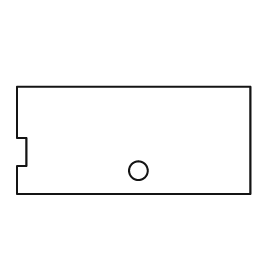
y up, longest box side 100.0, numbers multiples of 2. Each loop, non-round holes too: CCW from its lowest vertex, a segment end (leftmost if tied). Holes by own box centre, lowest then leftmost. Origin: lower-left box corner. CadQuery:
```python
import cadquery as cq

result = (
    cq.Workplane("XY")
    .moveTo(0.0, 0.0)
    .lineTo(100.0, 0.0)
    .lineTo(100.0, 46.0)
    .lineTo(0.0, 46.0)
    .lineTo(0.0, 24.0)
    .lineTo(4.0, 24.0)
    .lineTo(4.0, 12.0)
    .lineTo(0.0, 12.0)
    .close()
    .moveTo(52.0, 10.0)
    .circle(4.0)
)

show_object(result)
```